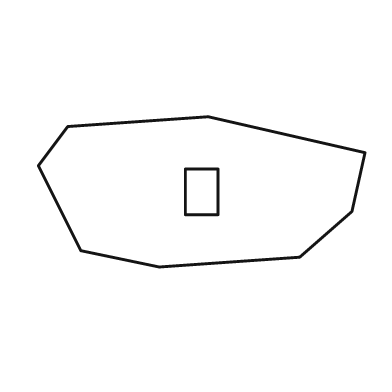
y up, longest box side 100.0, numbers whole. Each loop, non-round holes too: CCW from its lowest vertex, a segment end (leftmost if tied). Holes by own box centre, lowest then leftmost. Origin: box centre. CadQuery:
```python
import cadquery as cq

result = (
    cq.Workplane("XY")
    .moveTo(-13.0, -23.0)
    .lineTo(30.0, -20.0)
    .lineTo(46.0, -6.0)
    .lineTo(50.0, 12.0)
    .lineTo(2.0, 23.0)
    .lineTo(-41.0, 20.0)
    .lineTo(-50.0, 8.0)
    .lineTo(-37.0, -18.0)
    .close()
    .moveTo(-5.0, -7.0)
    .lineTo(5.0, -7.0)
    .lineTo(5.0, 7.0)
    .lineTo(-5.0, 7.0)
    .close()
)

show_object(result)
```